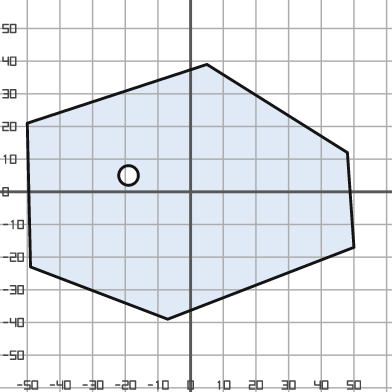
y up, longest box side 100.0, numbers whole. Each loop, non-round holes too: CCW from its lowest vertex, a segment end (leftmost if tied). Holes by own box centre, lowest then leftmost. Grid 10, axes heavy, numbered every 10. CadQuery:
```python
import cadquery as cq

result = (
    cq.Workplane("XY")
    .moveTo(-7.0, -39.0)
    .lineTo(50.0, -17.0)
    .lineTo(48.0, 12.0)
    .lineTo(5.0, 39.0)
    .lineTo(-50.0, 21.0)
    .lineTo(-49.0, -23.0)
    .close()
    .moveTo(-19.0, 5.0)
    .circle(3.0)
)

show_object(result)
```